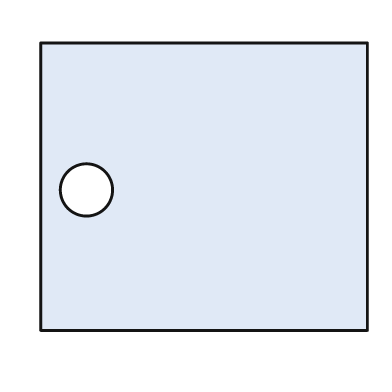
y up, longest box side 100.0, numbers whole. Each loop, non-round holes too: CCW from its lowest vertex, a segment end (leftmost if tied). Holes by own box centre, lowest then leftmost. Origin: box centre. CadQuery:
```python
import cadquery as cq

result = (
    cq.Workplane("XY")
    .moveTo(-50.0, -44.0)
    .lineTo(50.0, -44.0)
    .lineTo(50.0, 44.0)
    .lineTo(-50.0, 44.0)
    .close()
    .moveTo(-36.0, -1.0)
    .circle(8.0)
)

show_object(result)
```